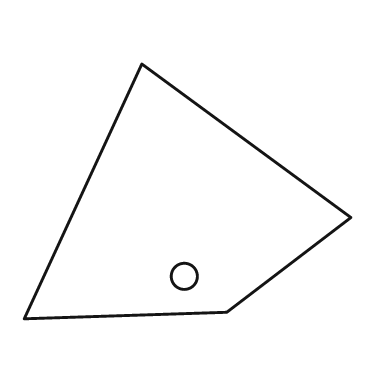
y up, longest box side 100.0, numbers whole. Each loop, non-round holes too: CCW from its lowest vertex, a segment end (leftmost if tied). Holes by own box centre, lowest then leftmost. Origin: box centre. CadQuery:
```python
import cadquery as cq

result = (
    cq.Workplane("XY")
    .moveTo(-50.0, -39.0)
    .lineTo(12.0, -37.0)
    .lineTo(50.0, -8.0)
    .lineTo(-14.0, 39.0)
    .close()
    .moveTo(-1.0, -26.0)
    .circle(4.0)
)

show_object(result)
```